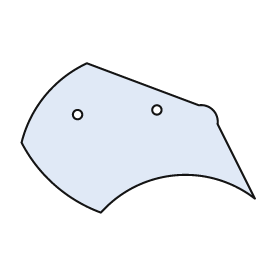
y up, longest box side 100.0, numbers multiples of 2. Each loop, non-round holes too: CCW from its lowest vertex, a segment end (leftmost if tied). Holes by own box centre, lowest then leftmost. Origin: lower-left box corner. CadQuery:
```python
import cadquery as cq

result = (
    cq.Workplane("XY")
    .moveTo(34.0, 0.0)
    .threePointArc((66.0, 16.0), (100.0, 6.0))
    .lineTo(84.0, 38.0)
    .threePointArc((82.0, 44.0), (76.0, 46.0))
    .lineTo(28.0, 64.0)
    .threePointArc((10.0, 50.0), (0.0, 30.0))
    .threePointArc((14.0, 12.0), (34.0, 0.0))
    .close()
    .moveTo(24.0, 42.0)
    .circle(2.0)
    .moveTo(58.0, 44.0)
    .circle(2.0)
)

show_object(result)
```